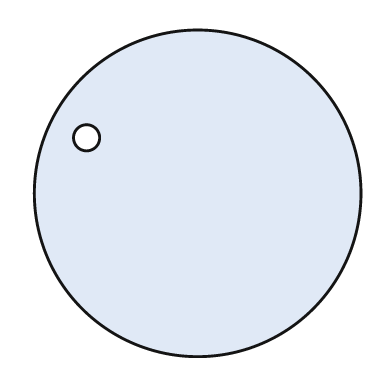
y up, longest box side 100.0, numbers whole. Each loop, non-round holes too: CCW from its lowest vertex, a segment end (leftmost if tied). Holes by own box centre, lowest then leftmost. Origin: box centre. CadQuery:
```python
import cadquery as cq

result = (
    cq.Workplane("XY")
    .moveTo(0.0, 0.0)
    .circle(50.0)
    .moveTo(-34.0, 17.0)
    .circle(4.0)
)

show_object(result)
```